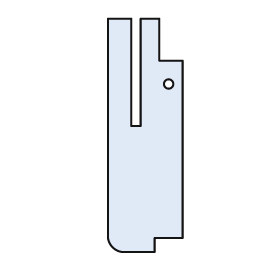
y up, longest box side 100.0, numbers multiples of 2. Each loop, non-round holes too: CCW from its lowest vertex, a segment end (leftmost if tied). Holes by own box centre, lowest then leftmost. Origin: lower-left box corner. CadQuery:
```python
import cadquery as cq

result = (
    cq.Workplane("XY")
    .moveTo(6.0, 0.0)
    .lineTo(20.0, 0.0)
    .lineTo(20.0, 6.0)
    .lineTo(32.0, 6.0)
    .lineTo(32.0, 82.0)
    .lineTo(22.0, 82.0)
    .lineTo(22.0, 100.0)
    .lineTo(14.0, 100.0)
    .lineTo(14.0, 54.0)
    .lineTo(10.0, 54.0)
    .lineTo(10.0, 100.0)
    .lineTo(0.0, 100.0)
    .lineTo(0.0, 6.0)
    .threePointArc((2.0, 2.0), (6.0, 0.0))
    .close()
    .moveTo(26.0, 72.0)
    .circle(2.0)
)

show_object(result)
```